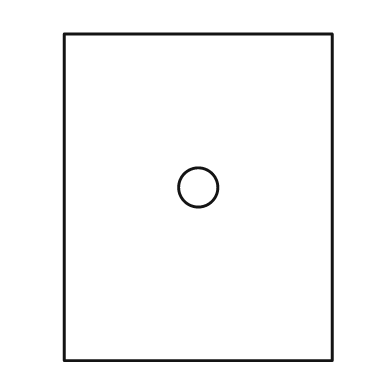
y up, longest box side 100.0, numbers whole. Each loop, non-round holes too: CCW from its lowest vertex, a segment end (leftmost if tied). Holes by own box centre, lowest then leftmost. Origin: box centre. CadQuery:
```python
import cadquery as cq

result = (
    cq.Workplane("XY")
    .moveTo(-41.0, -50.0)
    .lineTo(41.0, -50.0)
    .lineTo(41.0, 50.0)
    .lineTo(-41.0, 50.0)
    .close()
    .moveTo(0.0, 3.0)
    .circle(6.0)
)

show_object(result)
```